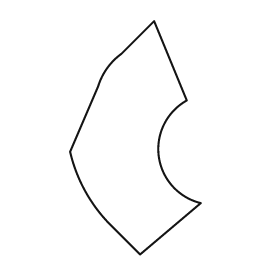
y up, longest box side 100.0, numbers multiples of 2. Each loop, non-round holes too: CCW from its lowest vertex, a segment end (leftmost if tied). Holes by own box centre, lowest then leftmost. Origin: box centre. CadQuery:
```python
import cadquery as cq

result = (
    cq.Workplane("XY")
    .moveTo(2.0, -50.0)
    .lineTo(28.0, -28.0)
    .threePointArc((10.0, -8.0), (22.0, 16.0))
    .lineTo(8.0, 50.0)
    .lineTo(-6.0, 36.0)
    .threePointArc((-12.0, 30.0), (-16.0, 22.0))
    .lineTo(-28.0, -6.0)
    .threePointArc((-22.0, -22.0), (-12.0, -36.0))
    .close()
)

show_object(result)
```